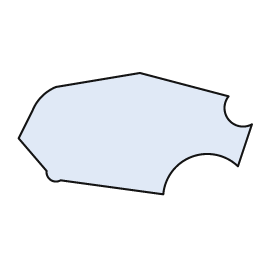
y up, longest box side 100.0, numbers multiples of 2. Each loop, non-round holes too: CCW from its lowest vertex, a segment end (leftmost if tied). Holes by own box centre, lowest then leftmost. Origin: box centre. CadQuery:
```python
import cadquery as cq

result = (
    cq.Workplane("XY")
    .moveTo(12.0, -26.0)
    .threePointArc((24.0, -10.0), (44.0, -14.0))
    .lineTo(50.0, 4.0)
    .threePointArc((40.0, 6.0), (40.0, 16.0))
    .lineTo(2.0, 26.0)
    .lineTo(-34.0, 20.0)
    .threePointArc((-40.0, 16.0), (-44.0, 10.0))
    .lineTo(-50.0, -2.0)
    .lineTo(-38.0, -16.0)
    .threePointArc((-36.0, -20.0), (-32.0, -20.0))
    .close()
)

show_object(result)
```